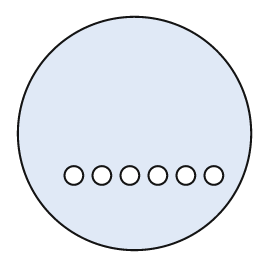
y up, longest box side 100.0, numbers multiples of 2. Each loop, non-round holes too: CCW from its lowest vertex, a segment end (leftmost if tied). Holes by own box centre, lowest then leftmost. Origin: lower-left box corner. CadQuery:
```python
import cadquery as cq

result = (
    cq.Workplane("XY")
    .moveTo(50.0, 50.0)
    .circle(50.0)
    .moveTo(24.0, 32.0)
    .circle(4.0)
    .moveTo(36.0, 32.0)
    .circle(4.0)
    .moveTo(48.0, 32.0)
    .circle(4.0)
    .moveTo(60.0, 32.0)
    .circle(4.0)
    .moveTo(72.0, 32.0)
    .circle(4.0)
    .moveTo(84.0, 32.0)
    .circle(4.0)
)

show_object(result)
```